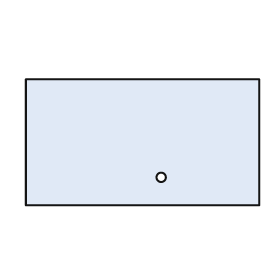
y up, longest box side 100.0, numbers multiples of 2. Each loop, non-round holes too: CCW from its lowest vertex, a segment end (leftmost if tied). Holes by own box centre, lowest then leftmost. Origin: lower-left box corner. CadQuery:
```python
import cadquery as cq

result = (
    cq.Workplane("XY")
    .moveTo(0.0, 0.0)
    .lineTo(100.0, 0.0)
    .lineTo(100.0, 54.0)
    .lineTo(0.0, 54.0)
    .close()
    .moveTo(58.0, 12.0)
    .circle(2.0)
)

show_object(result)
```